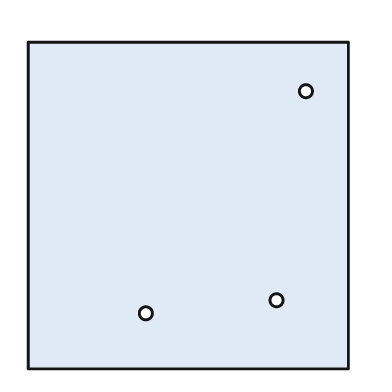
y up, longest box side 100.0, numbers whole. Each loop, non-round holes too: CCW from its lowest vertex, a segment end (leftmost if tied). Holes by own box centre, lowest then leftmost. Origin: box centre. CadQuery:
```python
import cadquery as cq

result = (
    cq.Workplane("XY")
    .moveTo(-49.0, -50.0)
    .lineTo(49.0, -50.0)
    .lineTo(49.0, 50.0)
    .lineTo(-49.0, 50.0)
    .close()
    .moveTo(-13.0, -33.0)
    .circle(2.0)
    .moveTo(27.0, -29.0)
    .circle(2.0)
    .moveTo(36.0, 35.0)
    .circle(2.0)
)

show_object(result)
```